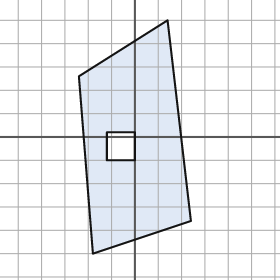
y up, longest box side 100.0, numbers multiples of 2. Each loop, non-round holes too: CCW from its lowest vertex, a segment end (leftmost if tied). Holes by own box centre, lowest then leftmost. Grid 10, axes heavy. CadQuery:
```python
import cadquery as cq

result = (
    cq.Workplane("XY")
    .moveTo(-18.0, -50.0)
    .lineTo(24.0, -36.0)
    .lineTo(14.0, 50.0)
    .lineTo(-24.0, 26.0)
    .close()
    .moveTo(-12.0, -10.0)
    .lineTo(0.0, -10.0)
    .lineTo(0.0, 2.0)
    .lineTo(-12.0, 2.0)
    .close()
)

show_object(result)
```